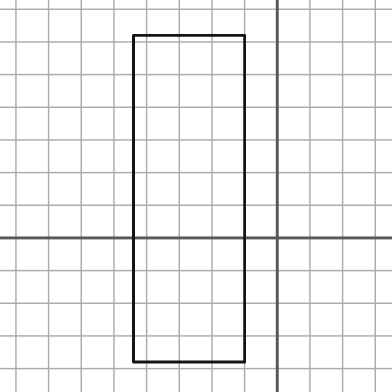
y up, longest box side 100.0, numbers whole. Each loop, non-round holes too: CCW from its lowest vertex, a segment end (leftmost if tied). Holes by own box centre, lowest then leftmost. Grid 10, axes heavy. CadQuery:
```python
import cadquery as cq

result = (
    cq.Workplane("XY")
    .moveTo(-44.0, -38.0)
    .lineTo(-10.0, -38.0)
    .lineTo(-10.0, 62.0)
    .lineTo(-44.0, 62.0)
    .close()
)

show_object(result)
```